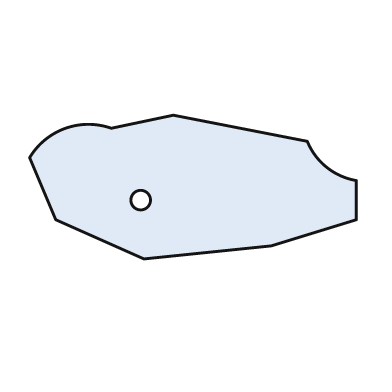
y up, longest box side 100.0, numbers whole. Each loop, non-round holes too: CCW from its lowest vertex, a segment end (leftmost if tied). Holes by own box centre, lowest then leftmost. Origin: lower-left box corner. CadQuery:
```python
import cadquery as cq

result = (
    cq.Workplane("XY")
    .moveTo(35.0, 0.0)
    .lineTo(74.0, 4.0)
    .lineTo(100.0, 12.0)
    .lineTo(100.0, 24.0)
    .threePointArc((91.0, 28.0), (85.0, 36.0))
    .lineTo(44.0, 44.0)
    .lineTo(25.0, 40.0)
    .threePointArc((11.0, 40.0), (0.0, 31.0))
    .lineTo(8.0, 12.0)
    .close()
    .moveTo(34.0, 18.0)
    .circle(3.0)
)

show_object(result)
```